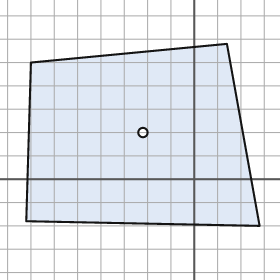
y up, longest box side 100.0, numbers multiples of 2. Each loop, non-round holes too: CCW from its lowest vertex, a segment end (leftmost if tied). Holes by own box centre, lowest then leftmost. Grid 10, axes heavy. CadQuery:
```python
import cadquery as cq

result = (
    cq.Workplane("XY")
    .moveTo(28.0, -20.0)
    .lineTo(14.0, 58.0)
    .lineTo(-70.0, 50.0)
    .lineTo(-72.0, -18.0)
    .close()
    .moveTo(-22.0, 20.0)
    .circle(2.0)
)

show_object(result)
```